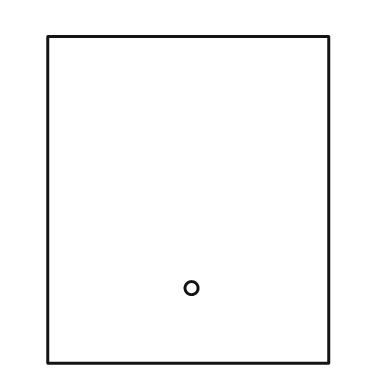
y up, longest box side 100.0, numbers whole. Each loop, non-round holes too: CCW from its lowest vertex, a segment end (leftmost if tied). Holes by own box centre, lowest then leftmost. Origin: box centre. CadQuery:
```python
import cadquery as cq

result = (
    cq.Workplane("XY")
    .moveTo(-43.0, -50.0)
    .lineTo(43.0, -50.0)
    .lineTo(43.0, 50.0)
    .lineTo(-43.0, 50.0)
    .close()
    .moveTo(1.0, -27.0)
    .circle(2.0)
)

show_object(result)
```